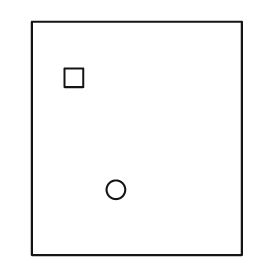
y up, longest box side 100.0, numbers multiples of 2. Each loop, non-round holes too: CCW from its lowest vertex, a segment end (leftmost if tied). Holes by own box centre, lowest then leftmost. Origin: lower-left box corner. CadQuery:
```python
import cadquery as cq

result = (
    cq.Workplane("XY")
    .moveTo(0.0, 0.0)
    .lineTo(90.0, 0.0)
    .lineTo(90.0, 100.0)
    .lineTo(0.0, 100.0)
    .close()
    .moveTo(36.0, 28.0)
    .circle(4.0)
    .moveTo(14.0, 72.0)
    .lineTo(22.0, 72.0)
    .lineTo(22.0, 80.0)
    .lineTo(14.0, 80.0)
    .close()
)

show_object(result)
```